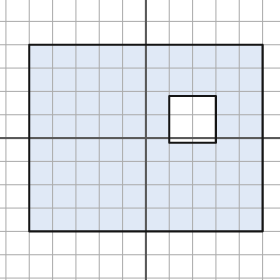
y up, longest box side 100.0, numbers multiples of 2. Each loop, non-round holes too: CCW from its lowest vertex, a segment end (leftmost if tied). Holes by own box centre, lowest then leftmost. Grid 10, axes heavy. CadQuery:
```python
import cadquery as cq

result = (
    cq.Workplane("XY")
    .moveTo(-50.0, -40.0)
    .lineTo(50.0, -40.0)
    .lineTo(50.0, 40.0)
    .lineTo(-50.0, 40.0)
    .close()
    .moveTo(10.0, -2.0)
    .lineTo(30.0, -2.0)
    .lineTo(30.0, 18.0)
    .lineTo(10.0, 18.0)
    .close()
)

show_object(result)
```